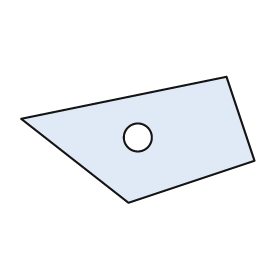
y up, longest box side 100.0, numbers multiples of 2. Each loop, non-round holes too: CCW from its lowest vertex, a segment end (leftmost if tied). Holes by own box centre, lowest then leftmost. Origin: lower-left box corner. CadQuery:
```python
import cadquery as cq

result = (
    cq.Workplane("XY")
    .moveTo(46.0, 0.0)
    .lineTo(100.0, 18.0)
    .lineTo(88.0, 54.0)
    .lineTo(0.0, 36.0)
    .close()
    .moveTo(50.0, 28.0)
    .circle(6.0)
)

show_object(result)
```